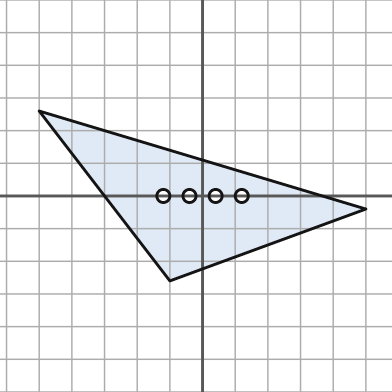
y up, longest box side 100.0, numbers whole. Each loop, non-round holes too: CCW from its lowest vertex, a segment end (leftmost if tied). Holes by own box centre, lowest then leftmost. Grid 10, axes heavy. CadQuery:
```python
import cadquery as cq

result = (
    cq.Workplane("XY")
    .moveTo(-10.0, -26.0)
    .lineTo(50.0, -4.0)
    .lineTo(-50.0, 26.0)
    .close()
    .moveTo(-12.0, 0.0)
    .circle(2.0)
    .moveTo(-4.0, 0.0)
    .circle(2.0)
    .moveTo(4.0, 0.0)
    .circle(2.0)
    .moveTo(12.0, 0.0)
    .circle(2.0)
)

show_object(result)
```